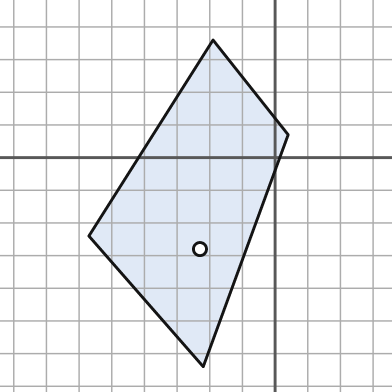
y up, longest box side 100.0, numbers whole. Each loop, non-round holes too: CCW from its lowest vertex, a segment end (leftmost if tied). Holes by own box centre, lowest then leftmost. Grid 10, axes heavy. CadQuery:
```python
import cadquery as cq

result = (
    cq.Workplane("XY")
    .moveTo(-22.0, -64.0)
    .lineTo(4.0, 7.0)
    .lineTo(-19.0, 36.0)
    .lineTo(-57.0, -24.0)
    .close()
    .moveTo(-23.0, -28.0)
    .circle(2.0)
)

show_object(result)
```